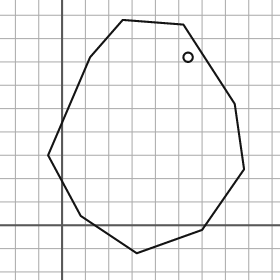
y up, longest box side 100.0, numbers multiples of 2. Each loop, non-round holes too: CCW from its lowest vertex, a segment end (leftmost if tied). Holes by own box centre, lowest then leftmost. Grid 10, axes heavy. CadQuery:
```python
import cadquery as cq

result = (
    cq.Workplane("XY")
    .moveTo(32.0, -12.0)
    .lineTo(60.0, -2.0)
    .lineTo(78.0, 24.0)
    .lineTo(74.0, 52.0)
    .lineTo(52.0, 86.0)
    .lineTo(26.0, 88.0)
    .lineTo(12.0, 72.0)
    .lineTo(-6.0, 30.0)
    .lineTo(8.0, 4.0)
    .close()
    .moveTo(54.0, 72.0)
    .circle(2.0)
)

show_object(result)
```